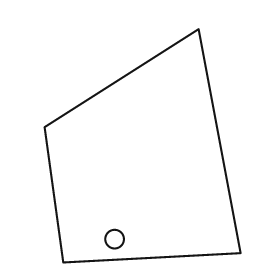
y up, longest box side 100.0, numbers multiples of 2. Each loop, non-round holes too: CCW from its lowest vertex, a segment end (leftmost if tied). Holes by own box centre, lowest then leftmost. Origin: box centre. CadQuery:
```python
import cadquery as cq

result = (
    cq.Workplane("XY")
    .moveTo(-34.0, -50.0)
    .lineTo(42.0, -46.0)
    .lineTo(24.0, 50.0)
    .lineTo(-42.0, 8.0)
    .close()
    .moveTo(-12.0, -40.0)
    .circle(4.0)
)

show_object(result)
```